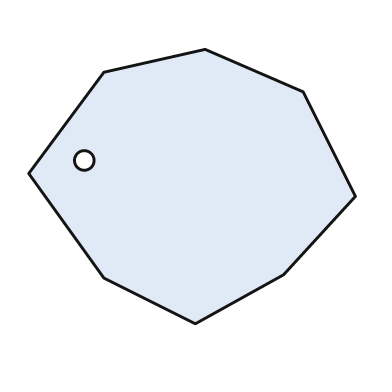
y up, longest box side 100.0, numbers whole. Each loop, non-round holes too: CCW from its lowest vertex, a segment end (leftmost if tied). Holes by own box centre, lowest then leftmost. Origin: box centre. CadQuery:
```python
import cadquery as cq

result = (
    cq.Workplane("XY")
    .moveTo(1.0, -42.0)
    .lineTo(28.0, -27.0)
    .lineTo(50.0, -3.0)
    .lineTo(34.0, 29.0)
    .lineTo(4.0, 42.0)
    .lineTo(-27.0, 35.0)
    .lineTo(-50.0, 4.0)
    .lineTo(-27.0, -28.0)
    .close()
    .moveTo(-33.0, 8.0)
    .circle(3.0)
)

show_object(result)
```